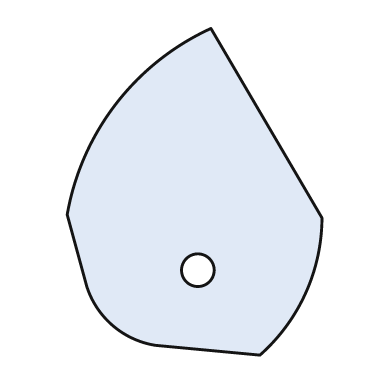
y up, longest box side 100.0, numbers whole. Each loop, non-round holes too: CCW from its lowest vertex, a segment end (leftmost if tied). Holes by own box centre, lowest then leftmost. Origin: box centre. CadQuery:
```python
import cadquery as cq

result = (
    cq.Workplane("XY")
    .moveTo(20.0, -50.0)
    .threePointArc((34.0, -31.0), (39.0, -8.0))
    .lineTo(5.0, 50.0)
    .threePointArc((-24.0, 27.0), (-39.0, -7.0))
    .lineTo(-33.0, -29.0)
    .threePointArc((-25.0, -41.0), (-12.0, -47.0))
    .close()
    .moveTo(1.0, -24.0)
    .circle(5.0)
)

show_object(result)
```